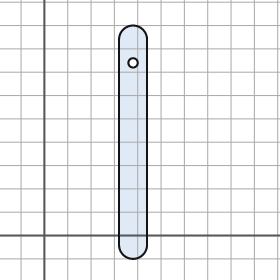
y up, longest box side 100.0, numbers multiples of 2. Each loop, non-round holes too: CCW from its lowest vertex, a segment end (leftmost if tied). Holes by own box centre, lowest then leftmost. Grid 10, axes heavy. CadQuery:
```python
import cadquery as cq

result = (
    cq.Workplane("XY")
    .moveTo(32.0, -4.0)
    .threePointArc((38.0, -10.0), (44.0, -4.0))
    .lineTo(44.0, 84.0)
    .threePointArc((38.0, 90.0), (32.0, 84.0))
    .close()
    .moveTo(38.0, 74.0)
    .circle(2.0)
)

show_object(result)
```